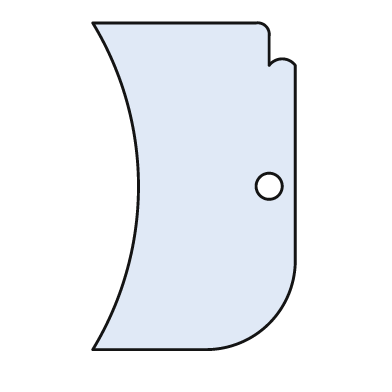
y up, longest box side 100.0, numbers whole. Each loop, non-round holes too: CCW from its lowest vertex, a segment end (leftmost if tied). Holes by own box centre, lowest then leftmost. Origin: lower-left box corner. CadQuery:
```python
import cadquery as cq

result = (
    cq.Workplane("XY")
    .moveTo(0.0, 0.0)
    .lineTo(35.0, 0.0)
    .threePointArc((54.0, 8.0), (62.0, 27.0))
    .lineTo(62.0, 87.0)
    .threePointArc((58.0, 89.0), (54.0, 87.0))
    .lineTo(54.0, 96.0)
    .threePointArc((53.0, 99.0), (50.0, 100.0))
    .lineTo(0.0, 100.0)
    .threePointArc((14.0, 50.0), (0.0, 0.0))
    .close()
    .moveTo(54.0, 50.0)
    .circle(4.0)
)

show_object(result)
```